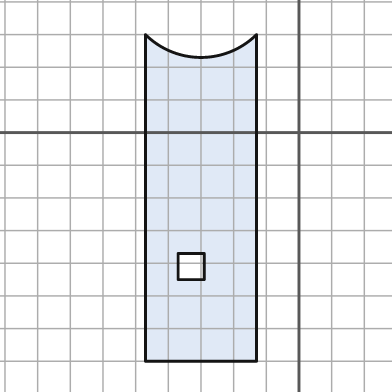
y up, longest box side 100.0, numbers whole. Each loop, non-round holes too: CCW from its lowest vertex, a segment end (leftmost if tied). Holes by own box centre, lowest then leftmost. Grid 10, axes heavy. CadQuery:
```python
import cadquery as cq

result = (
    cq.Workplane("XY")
    .moveTo(-47.0, -70.0)
    .lineTo(-13.0, -70.0)
    .lineTo(-13.0, 30.0)
    .threePointArc((-30.0, 23.0), (-47.0, 30.0))
    .close()
    .moveTo(-37.0, -45.0)
    .lineTo(-29.0, -45.0)
    .lineTo(-29.0, -37.0)
    .lineTo(-37.0, -37.0)
    .close()
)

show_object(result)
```